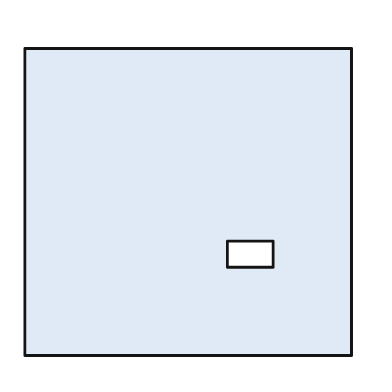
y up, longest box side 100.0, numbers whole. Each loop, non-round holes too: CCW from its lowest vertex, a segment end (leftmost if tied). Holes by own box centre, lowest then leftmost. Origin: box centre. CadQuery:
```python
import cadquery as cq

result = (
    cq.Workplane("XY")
    .moveTo(-50.0, -47.0)
    .lineTo(50.0, -47.0)
    .lineTo(50.0, 47.0)
    .lineTo(-50.0, 47.0)
    .close()
    .moveTo(12.0, -20.0)
    .lineTo(26.0, -20.0)
    .lineTo(26.0, -12.0)
    .lineTo(12.0, -12.0)
    .close()
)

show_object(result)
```